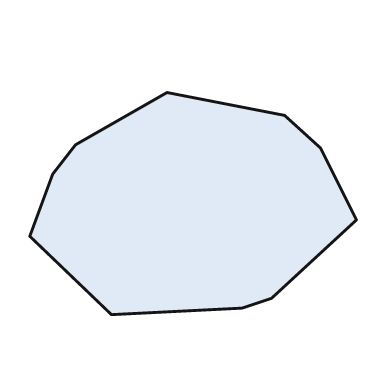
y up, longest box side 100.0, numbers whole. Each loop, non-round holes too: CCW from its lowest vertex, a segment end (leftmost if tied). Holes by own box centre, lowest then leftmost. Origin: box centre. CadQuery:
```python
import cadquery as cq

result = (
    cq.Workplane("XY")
    .moveTo(-25.0, -34.0)
    .lineTo(15.0, -32.0)
    .lineTo(24.0, -29.0)
    .lineTo(50.0, -5.0)
    .lineTo(39.0, 17.0)
    .lineTo(28.0, 27.0)
    .lineTo(-8.0, 34.0)
    .lineTo(-36.0, 18.0)
    .lineTo(-43.0, 9.0)
    .lineTo(-50.0, -10.0)
    .close()
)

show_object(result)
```